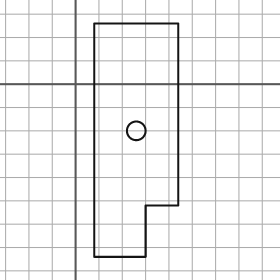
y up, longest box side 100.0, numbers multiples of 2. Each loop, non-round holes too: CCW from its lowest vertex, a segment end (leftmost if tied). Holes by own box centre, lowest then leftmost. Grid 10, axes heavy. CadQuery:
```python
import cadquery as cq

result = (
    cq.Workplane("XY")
    .moveTo(8.0, -74.0)
    .lineTo(30.0, -74.0)
    .lineTo(30.0, -52.0)
    .lineTo(44.0, -52.0)
    .lineTo(44.0, 26.0)
    .lineTo(8.0, 26.0)
    .close()
    .moveTo(26.0, -20.0)
    .circle(4.0)
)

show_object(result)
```